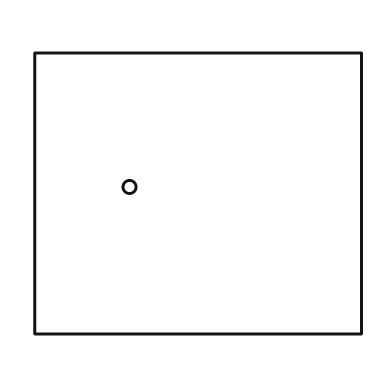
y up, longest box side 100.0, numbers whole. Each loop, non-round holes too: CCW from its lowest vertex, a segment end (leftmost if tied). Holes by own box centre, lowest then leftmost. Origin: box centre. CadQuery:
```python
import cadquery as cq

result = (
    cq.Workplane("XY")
    .moveTo(-50.0, -43.0)
    .lineTo(50.0, -43.0)
    .lineTo(50.0, 43.0)
    .lineTo(-50.0, 43.0)
    .close()
    .moveTo(-21.0, 2.0)
    .circle(2.0)
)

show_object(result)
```